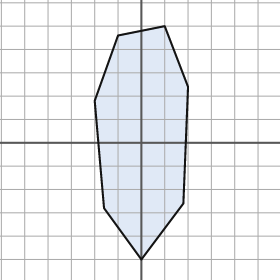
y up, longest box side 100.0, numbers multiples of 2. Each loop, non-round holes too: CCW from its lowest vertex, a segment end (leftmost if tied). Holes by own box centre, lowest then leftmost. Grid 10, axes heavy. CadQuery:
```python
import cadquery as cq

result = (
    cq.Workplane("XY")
    .moveTo(0.0, -50.0)
    .lineTo(18.0, -26.0)
    .lineTo(20.0, 24.0)
    .lineTo(10.0, 50.0)
    .lineTo(-10.0, 46.0)
    .lineTo(-20.0, 18.0)
    .lineTo(-16.0, -28.0)
    .close()
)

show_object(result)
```